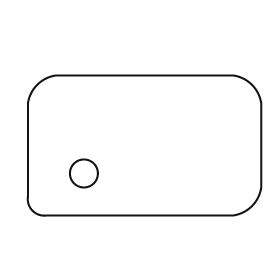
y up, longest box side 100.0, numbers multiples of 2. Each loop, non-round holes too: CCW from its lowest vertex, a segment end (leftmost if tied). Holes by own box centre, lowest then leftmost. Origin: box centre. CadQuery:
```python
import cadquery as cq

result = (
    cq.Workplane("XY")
    .moveTo(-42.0, -30.0)
    .lineTo(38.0, -30.0)
    .threePointArc((46.0, -26.0), (50.0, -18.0))
    .lineTo(50.0, 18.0)
    .threePointArc((46.0, 26.0), (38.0, 30.0))
    .lineTo(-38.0, 30.0)
    .threePointArc((-46.0, 26.0), (-50.0, 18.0))
    .lineTo(-50.0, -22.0)
    .threePointArc((-48.0, -28.0), (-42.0, -30.0))
    .close()
    .moveTo(-26.0, -12.0)
    .circle(6.0)
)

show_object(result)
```